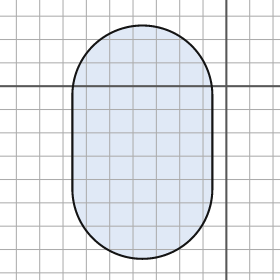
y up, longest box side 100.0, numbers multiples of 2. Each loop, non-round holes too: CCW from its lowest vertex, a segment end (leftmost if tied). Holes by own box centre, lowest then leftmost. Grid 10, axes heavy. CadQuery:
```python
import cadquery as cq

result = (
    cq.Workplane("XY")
    .moveTo(-66.0, -44.0)
    .threePointArc((-36.0, -74.0), (-6.0, -44.0))
    .lineTo(-6.0, -4.0)
    .threePointArc((-36.0, 26.0), (-66.0, -4.0))
    .close()
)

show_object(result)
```